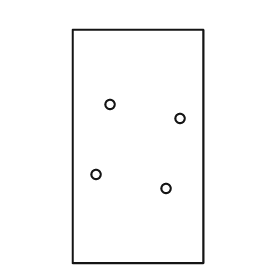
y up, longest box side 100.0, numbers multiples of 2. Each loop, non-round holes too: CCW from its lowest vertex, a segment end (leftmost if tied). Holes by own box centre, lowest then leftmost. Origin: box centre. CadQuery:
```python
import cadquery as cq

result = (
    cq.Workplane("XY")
    .moveTo(-28.0, -50.0)
    .lineTo(28.0, -50.0)
    .lineTo(28.0, 50.0)
    .lineTo(-28.0, 50.0)
    .close()
    .moveTo(12.0, -18.0)
    .circle(2.0)
    .moveTo(-18.0, -12.0)
    .circle(2.0)
    .moveTo(18.0, 12.0)
    .circle(2.0)
    .moveTo(-12.0, 18.0)
    .circle(2.0)
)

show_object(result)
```